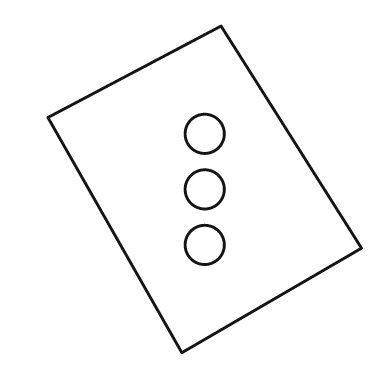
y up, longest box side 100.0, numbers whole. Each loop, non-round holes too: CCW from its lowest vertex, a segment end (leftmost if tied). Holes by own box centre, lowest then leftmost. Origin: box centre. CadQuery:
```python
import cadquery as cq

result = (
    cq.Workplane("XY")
    .moveTo(-7.0, -50.0)
    .lineTo(48.0, -18.0)
    .lineTo(5.0, 50.0)
    .lineTo(-48.0, 22.0)
    .close()
    .moveTo(0.0, -17.0)
    .circle(6.0)
    .moveTo(0.0, 0.0)
    .circle(6.0)
    .moveTo(0.0, 17.0)
    .circle(6.0)
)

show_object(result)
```